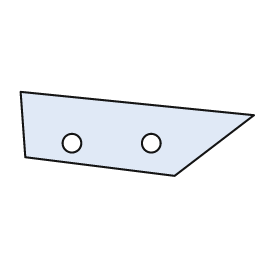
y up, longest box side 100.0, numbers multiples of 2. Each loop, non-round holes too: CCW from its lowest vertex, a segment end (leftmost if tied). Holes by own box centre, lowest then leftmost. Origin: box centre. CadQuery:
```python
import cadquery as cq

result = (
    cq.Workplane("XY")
    .moveTo(16.0, -18.0)
    .lineTo(50.0, 8.0)
    .lineTo(-50.0, 18.0)
    .lineTo(-48.0, -10.0)
    .close()
    .moveTo(-28.0, -4.0)
    .circle(4.0)
    .moveTo(6.0, -4.0)
    .circle(4.0)
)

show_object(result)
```